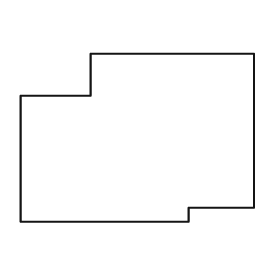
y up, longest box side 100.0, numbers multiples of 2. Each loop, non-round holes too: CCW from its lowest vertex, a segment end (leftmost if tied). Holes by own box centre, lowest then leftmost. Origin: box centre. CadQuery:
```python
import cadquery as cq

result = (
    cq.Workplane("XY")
    .moveTo(-50.0, -36.0)
    .lineTo(22.0, -36.0)
    .lineTo(22.0, -30.0)
    .lineTo(50.0, -30.0)
    .lineTo(50.0, 36.0)
    .lineTo(-20.0, 36.0)
    .lineTo(-20.0, 18.0)
    .lineTo(-50.0, 18.0)
    .close()
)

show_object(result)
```